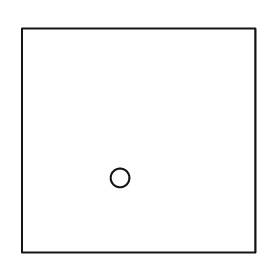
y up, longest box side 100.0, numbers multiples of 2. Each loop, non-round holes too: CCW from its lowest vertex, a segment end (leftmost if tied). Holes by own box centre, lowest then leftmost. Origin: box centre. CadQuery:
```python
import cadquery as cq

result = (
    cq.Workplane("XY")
    .moveTo(-50.0, -48.0)
    .lineTo(50.0, -48.0)
    .lineTo(50.0, 48.0)
    .lineTo(-50.0, 48.0)
    .close()
    .moveTo(-8.0, -16.0)
    .circle(4.0)
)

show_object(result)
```